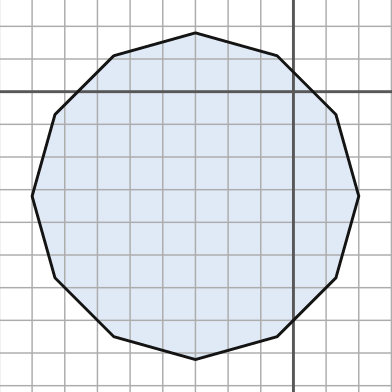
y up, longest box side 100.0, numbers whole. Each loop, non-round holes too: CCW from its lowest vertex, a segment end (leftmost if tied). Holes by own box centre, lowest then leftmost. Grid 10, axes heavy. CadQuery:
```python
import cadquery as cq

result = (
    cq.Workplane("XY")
    .moveTo(-30.0, -82.0)
    .lineTo(-5.0, -75.0)
    .lineTo(13.0, -57.0)
    .lineTo(20.0, -32.0)
    .lineTo(13.0, -7.0)
    .lineTo(-5.0, 11.0)
    .lineTo(-30.0, 18.0)
    .lineTo(-55.0, 11.0)
    .lineTo(-73.0, -7.0)
    .lineTo(-80.0, -32.0)
    .lineTo(-73.0, -57.0)
    .lineTo(-55.0, -75.0)
    .close()
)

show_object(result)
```